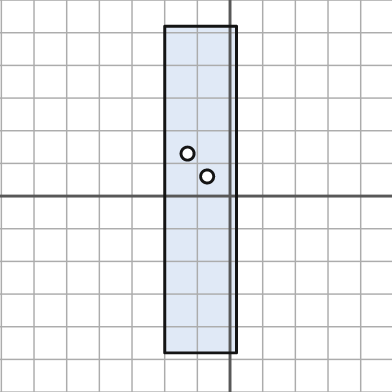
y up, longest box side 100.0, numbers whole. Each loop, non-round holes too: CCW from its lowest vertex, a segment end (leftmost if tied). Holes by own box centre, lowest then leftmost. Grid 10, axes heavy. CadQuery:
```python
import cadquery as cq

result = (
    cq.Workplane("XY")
    .moveTo(-20.0, -48.0)
    .lineTo(2.0, -48.0)
    .lineTo(2.0, 52.0)
    .lineTo(-20.0, 52.0)
    .close()
    .moveTo(-7.0, 6.0)
    .circle(2.0)
    .moveTo(-13.0, 13.0)
    .circle(2.0)
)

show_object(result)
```